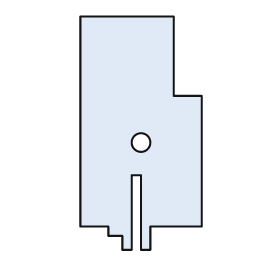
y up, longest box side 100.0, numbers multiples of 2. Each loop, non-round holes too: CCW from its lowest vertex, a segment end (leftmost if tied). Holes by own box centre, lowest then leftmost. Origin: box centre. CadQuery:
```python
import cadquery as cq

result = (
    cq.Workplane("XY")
    .moveTo(-8.0, -50.0)
    .lineTo(-4.0, -50.0)
    .lineTo(-4.0, -18.0)
    .lineTo(0.0, -18.0)
    .lineTo(0.0, -50.0)
    .lineTo(4.0, -50.0)
    .lineTo(4.0, -40.0)
    .lineTo(26.0, -40.0)
    .lineTo(26.0, 16.0)
    .lineTo(14.0, 16.0)
    .lineTo(14.0, 50.0)
    .lineTo(-26.0, 50.0)
    .lineTo(-26.0, -40.0)
    .lineTo(-14.0, -40.0)
    .lineTo(-14.0, -44.0)
    .lineTo(-8.0, -44.0)
    .close()
    .moveTo(0.0, -4.0)
    .circle(4.0)
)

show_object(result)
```